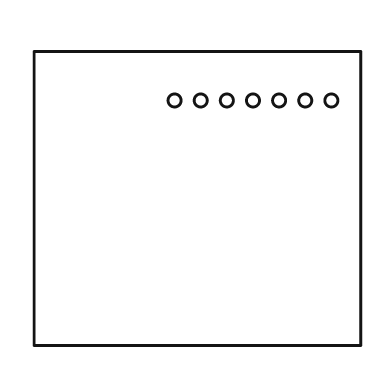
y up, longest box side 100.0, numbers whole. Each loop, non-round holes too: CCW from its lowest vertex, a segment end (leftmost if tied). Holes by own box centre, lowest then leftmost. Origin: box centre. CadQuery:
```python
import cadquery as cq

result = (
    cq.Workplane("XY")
    .moveTo(-50.0, -45.0)
    .lineTo(50.0, -45.0)
    .lineTo(50.0, 45.0)
    .lineTo(-50.0, 45.0)
    .close()
    .moveTo(-7.0, 30.0)
    .circle(2.0)
    .moveTo(1.0, 30.0)
    .circle(2.0)
    .moveTo(9.0, 30.0)
    .circle(2.0)
    .moveTo(17.0, 30.0)
    .circle(2.0)
    .moveTo(25.0, 30.0)
    .circle(2.0)
    .moveTo(33.0, 30.0)
    .circle(2.0)
    .moveTo(41.0, 30.0)
    .circle(2.0)
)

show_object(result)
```